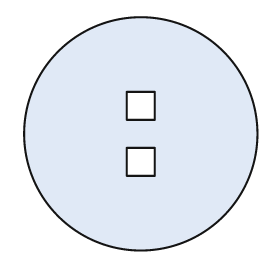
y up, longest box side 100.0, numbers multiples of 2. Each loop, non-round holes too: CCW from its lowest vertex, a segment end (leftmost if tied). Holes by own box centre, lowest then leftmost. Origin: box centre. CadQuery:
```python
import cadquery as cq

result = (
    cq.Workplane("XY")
    .moveTo(0.0, 0.0)
    .circle(50.0)
    .moveTo(-6.0, -18.0)
    .lineTo(6.0, -18.0)
    .lineTo(6.0, -6.0)
    .lineTo(-6.0, -6.0)
    .close()
    .moveTo(-6.0, 6.0)
    .lineTo(6.0, 6.0)
    .lineTo(6.0, 18.0)
    .lineTo(-6.0, 18.0)
    .close()
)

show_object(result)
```